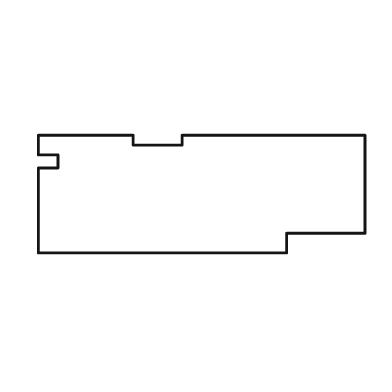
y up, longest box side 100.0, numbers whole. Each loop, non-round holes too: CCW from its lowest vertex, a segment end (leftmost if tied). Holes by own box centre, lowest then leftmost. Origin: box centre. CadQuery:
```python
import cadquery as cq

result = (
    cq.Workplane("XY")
    .moveTo(-50.0, -18.0)
    .lineTo(26.0, -18.0)
    .lineTo(26.0, -12.0)
    .lineTo(50.0, -12.0)
    .lineTo(50.0, 18.0)
    .lineTo(-6.0, 18.0)
    .lineTo(-6.0, 15.0)
    .lineTo(-21.0, 15.0)
    .lineTo(-21.0, 18.0)
    .lineTo(-50.0, 18.0)
    .lineTo(-50.0, 12.0)
    .lineTo(-44.0, 12.0)
    .lineTo(-44.0, 8.0)
    .lineTo(-50.0, 8.0)
    .close()
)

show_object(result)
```